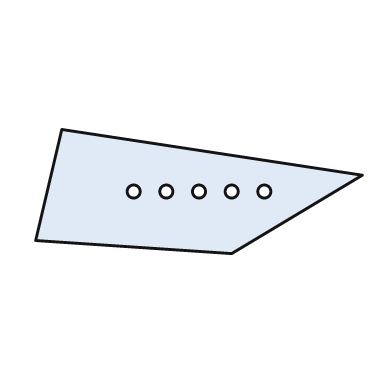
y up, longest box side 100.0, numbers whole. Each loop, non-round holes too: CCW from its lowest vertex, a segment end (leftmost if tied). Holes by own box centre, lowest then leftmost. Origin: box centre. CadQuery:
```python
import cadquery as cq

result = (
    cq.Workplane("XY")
    .moveTo(10.0, -19.0)
    .lineTo(50.0, 5.0)
    .lineTo(-42.0, 19.0)
    .lineTo(-50.0, -15.0)
    .close()
    .moveTo(-20.0, 0.0)
    .circle(2.0)
    .moveTo(-10.0, 0.0)
    .circle(2.0)
    .moveTo(0.0, 0.0)
    .circle(2.0)
    .moveTo(10.0, 0.0)
    .circle(2.0)
    .moveTo(20.0, 0.0)
    .circle(2.0)
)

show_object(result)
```